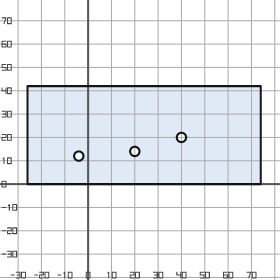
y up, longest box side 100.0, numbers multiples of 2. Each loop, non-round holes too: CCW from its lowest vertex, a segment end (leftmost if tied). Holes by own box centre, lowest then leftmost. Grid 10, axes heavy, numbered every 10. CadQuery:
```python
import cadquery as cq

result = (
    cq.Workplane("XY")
    .moveTo(-26.0, 0.0)
    .lineTo(74.0, 0.0)
    .lineTo(74.0, 42.0)
    .lineTo(-26.0, 42.0)
    .close()
    .moveTo(-4.0, 12.0)
    .circle(2.0)
    .moveTo(20.0, 14.0)
    .circle(2.0)
    .moveTo(40.0, 20.0)
    .circle(2.0)
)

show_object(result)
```